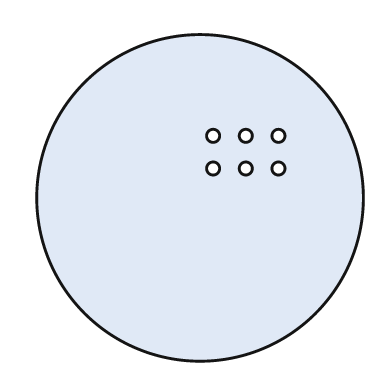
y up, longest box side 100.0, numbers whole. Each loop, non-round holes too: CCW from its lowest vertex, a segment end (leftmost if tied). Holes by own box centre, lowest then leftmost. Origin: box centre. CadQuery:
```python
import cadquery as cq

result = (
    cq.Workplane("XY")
    .moveTo(0.0, 0.0)
    .circle(50.0)
    .moveTo(4.0, 9.0)
    .circle(2.0)
    .moveTo(14.0, 9.0)
    .circle(2.0)
    .moveTo(24.0, 9.0)
    .circle(2.0)
    .moveTo(4.0, 19.0)
    .circle(2.0)
    .moveTo(14.0, 19.0)
    .circle(2.0)
    .moveTo(24.0, 19.0)
    .circle(2.0)
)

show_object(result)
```